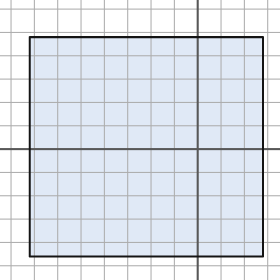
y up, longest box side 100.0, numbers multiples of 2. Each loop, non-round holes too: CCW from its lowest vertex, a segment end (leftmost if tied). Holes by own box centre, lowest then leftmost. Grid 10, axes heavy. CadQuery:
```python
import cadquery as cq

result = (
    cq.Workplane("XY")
    .moveTo(-72.0, -46.0)
    .lineTo(28.0, -46.0)
    .lineTo(28.0, 48.0)
    .lineTo(-72.0, 48.0)
    .close()
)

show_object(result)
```